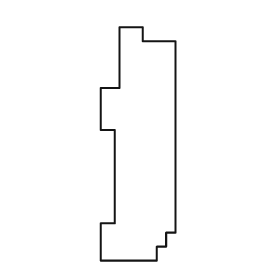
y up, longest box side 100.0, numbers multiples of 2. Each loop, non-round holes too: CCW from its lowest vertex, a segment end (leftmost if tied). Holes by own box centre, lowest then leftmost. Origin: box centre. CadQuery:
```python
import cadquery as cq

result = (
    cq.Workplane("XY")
    .moveTo(-16.0, -50.0)
    .lineTo(8.0, -50.0)
    .lineTo(8.0, -44.0)
    .lineTo(12.0, -44.0)
    .lineTo(12.0, -38.0)
    .lineTo(16.0, -38.0)
    .lineTo(16.0, 44.0)
    .lineTo(2.0, 44.0)
    .lineTo(2.0, 50.0)
    .lineTo(-8.0, 50.0)
    .lineTo(-8.0, 24.0)
    .lineTo(-16.0, 24.0)
    .lineTo(-16.0, 6.0)
    .lineTo(-10.0, 6.0)
    .lineTo(-10.0, -34.0)
    .lineTo(-16.0, -34.0)
    .close()
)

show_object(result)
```